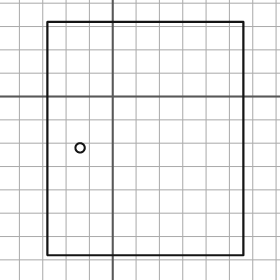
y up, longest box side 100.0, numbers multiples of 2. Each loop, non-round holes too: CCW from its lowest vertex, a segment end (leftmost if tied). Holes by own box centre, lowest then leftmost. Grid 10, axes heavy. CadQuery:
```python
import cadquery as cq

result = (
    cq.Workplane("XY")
    .moveTo(-28.0, -68.0)
    .lineTo(56.0, -68.0)
    .lineTo(56.0, 32.0)
    .lineTo(-28.0, 32.0)
    .close()
    .moveTo(-14.0, -22.0)
    .circle(2.0)
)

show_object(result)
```